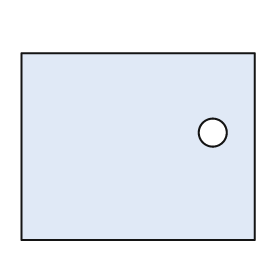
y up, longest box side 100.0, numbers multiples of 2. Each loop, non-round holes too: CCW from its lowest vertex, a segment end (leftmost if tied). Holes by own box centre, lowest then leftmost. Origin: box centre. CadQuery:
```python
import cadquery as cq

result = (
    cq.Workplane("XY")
    .moveTo(-50.0, -40.0)
    .lineTo(50.0, -40.0)
    .lineTo(50.0, 40.0)
    .lineTo(-50.0, 40.0)
    .close()
    .moveTo(32.0, 6.0)
    .circle(6.0)
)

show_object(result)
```